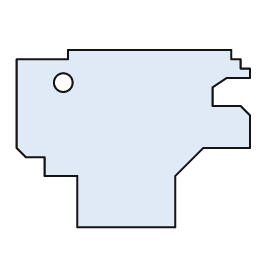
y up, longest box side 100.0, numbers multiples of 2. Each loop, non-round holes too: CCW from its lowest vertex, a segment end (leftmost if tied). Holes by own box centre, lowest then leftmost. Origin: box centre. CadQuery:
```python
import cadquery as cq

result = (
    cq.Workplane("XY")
    .moveTo(-24.0, -38.0)
    .lineTo(18.0, -38.0)
    .lineTo(18.0, -16.0)
    .lineTo(30.0, -4.0)
    .lineTo(50.0, -4.0)
    .lineTo(50.0, 10.0)
    .lineTo(46.0, 14.0)
    .lineTo(34.0, 14.0)
    .lineTo(34.0, 22.0)
    .lineTo(40.0, 26.0)
    .lineTo(50.0, 26.0)
    .lineTo(50.0, 30.0)
    .lineTo(46.0, 30.0)
    .lineTo(46.0, 34.0)
    .lineTo(42.0, 34.0)
    .lineTo(42.0, 38.0)
    .lineTo(-28.0, 38.0)
    .lineTo(-28.0, 34.0)
    .lineTo(-50.0, 34.0)
    .lineTo(-50.0, -4.0)
    .lineTo(-46.0, -8.0)
    .lineTo(-38.0, -8.0)
    .lineTo(-38.0, -16.0)
    .lineTo(-24.0, -16.0)
    .close()
    .moveTo(-30.0, 24.0)
    .circle(4.0)
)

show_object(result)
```